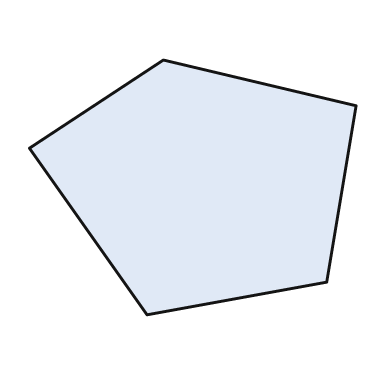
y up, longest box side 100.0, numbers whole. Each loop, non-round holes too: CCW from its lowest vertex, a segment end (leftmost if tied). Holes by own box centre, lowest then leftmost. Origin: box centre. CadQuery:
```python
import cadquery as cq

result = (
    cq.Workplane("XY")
    .moveTo(-14.0, -39.0)
    .lineTo(41.0, -29.0)
    .lineTo(50.0, 25.0)
    .lineTo(-9.0, 39.0)
    .lineTo(-50.0, 12.0)
    .close()
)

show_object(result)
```